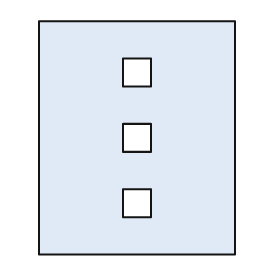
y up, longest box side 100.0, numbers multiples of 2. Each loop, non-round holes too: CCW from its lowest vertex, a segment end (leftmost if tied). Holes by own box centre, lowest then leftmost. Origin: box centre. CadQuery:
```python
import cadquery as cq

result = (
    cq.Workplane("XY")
    .moveTo(-42.0, -50.0)
    .lineTo(42.0, -50.0)
    .lineTo(42.0, 50.0)
    .lineTo(-42.0, 50.0)
    .close()
    .moveTo(-6.0, -34.0)
    .lineTo(6.0, -34.0)
    .lineTo(6.0, -22.0)
    .lineTo(-6.0, -22.0)
    .close()
    .moveTo(-6.0, -6.0)
    .lineTo(6.0, -6.0)
    .lineTo(6.0, 6.0)
    .lineTo(-6.0, 6.0)
    .close()
    .moveTo(-6.0, 22.0)
    .lineTo(6.0, 22.0)
    .lineTo(6.0, 34.0)
    .lineTo(-6.0, 34.0)
    .close()
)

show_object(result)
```